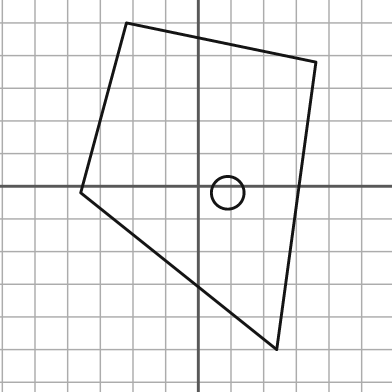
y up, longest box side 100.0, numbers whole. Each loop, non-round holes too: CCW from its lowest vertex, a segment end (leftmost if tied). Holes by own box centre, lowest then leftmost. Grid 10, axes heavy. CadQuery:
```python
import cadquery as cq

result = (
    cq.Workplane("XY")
    .moveTo(24.0, -50.0)
    .lineTo(36.0, 38.0)
    .lineTo(-22.0, 50.0)
    .lineTo(-36.0, -2.0)
    .close()
    .moveTo(9.0, -2.0)
    .circle(5.0)
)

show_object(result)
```